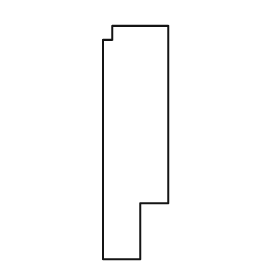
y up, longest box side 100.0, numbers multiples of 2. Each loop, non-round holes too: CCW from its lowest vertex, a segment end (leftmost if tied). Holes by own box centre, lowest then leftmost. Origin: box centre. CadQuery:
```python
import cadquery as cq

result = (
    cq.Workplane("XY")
    .moveTo(-14.0, -50.0)
    .lineTo(2.0, -50.0)
    .lineTo(2.0, -26.0)
    .lineTo(14.0, -26.0)
    .lineTo(14.0, 50.0)
    .lineTo(-10.0, 50.0)
    .lineTo(-10.0, 44.0)
    .lineTo(-14.0, 44.0)
    .close()
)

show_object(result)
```